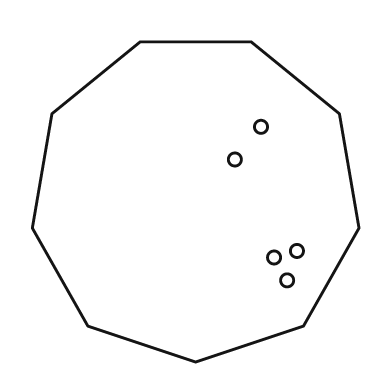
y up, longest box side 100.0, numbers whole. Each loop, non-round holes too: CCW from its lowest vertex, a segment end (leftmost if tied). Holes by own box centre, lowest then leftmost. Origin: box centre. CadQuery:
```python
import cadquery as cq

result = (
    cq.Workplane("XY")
    .moveTo(0.0, -49.0)
    .lineTo(33.0, -38.0)
    .lineTo(50.0, -8.0)
    .lineTo(44.0, 27.0)
    .lineTo(17.0, 49.0)
    .lineTo(-17.0, 49.0)
    .lineTo(-44.0, 27.0)
    .lineTo(-50.0, -8.0)
    .lineTo(-33.0, -38.0)
    .close()
    .moveTo(28.0, -24.0)
    .circle(2.0)
    .moveTo(24.0, -17.0)
    .circle(2.0)
    .moveTo(31.0, -15.0)
    .circle(2.0)
    .moveTo(12.0, 13.0)
    .circle(2.0)
    .moveTo(20.0, 23.0)
    .circle(2.0)
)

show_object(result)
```